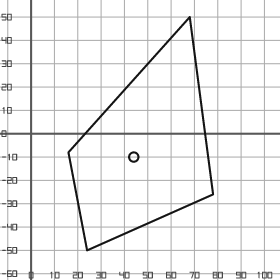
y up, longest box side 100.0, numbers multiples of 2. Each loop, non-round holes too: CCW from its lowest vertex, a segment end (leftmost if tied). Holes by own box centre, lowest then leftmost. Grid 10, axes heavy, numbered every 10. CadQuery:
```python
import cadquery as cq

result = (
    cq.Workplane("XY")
    .moveTo(24.0, -50.0)
    .lineTo(78.0, -26.0)
    .lineTo(68.0, 50.0)
    .lineTo(16.0, -8.0)
    .close()
    .moveTo(44.0, -10.0)
    .circle(2.0)
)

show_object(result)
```